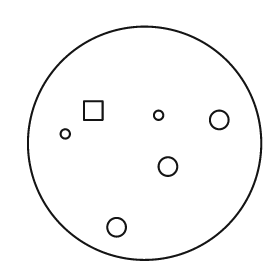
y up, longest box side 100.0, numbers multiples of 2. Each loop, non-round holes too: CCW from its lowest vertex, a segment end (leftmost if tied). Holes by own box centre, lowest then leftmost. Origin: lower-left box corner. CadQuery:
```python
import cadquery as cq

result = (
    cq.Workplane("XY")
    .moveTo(50.0, 50.0)
    .circle(50.0)
    .moveTo(38.0, 14.0)
    .circle(4.0)
    .moveTo(60.0, 40.0)
    .circle(4.0)
    .moveTo(16.0, 54.0)
    .circle(2.0)
    .moveTo(82.0, 60.0)
    .circle(4.0)
    .moveTo(56.0, 62.0)
    .circle(2.0)
    .moveTo(24.0, 60.0)
    .lineTo(32.0, 60.0)
    .lineTo(32.0, 68.0)
    .lineTo(24.0, 68.0)
    .close()
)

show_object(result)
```